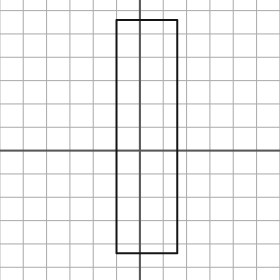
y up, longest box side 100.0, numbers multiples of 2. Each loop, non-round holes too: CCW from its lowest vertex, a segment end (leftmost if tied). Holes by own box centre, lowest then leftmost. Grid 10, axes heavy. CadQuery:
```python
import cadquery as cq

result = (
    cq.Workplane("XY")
    .moveTo(-10.0, -44.0)
    .lineTo(16.0, -44.0)
    .lineTo(16.0, 56.0)
    .lineTo(-10.0, 56.0)
    .close()
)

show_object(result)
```